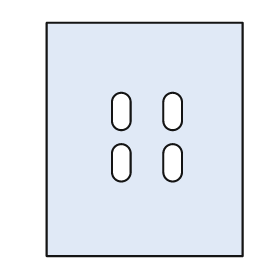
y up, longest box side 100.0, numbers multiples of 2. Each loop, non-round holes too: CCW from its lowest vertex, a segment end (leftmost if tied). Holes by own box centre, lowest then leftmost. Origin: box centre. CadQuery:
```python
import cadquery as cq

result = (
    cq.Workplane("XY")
    .moveTo(-42.0, -50.0)
    .lineTo(42.0, -50.0)
    .lineTo(42.0, 50.0)
    .lineTo(-42.0, 50.0)
    .close()
    .moveTo(-14.0, -14.0)
    .threePointArc((-10.0, -18.0), (-6.0, -14.0))
    .lineTo(-6.0, -6.0)
    .threePointArc((-10.0, -2.0), (-14.0, -6.0))
    .close()
    .moveTo(8.0, -14.0)
    .threePointArc((12.0, -18.0), (16.0, -14.0))
    .lineTo(16.0, -6.0)
    .threePointArc((12.0, -2.0), (8.0, -6.0))
    .close()
    .moveTo(-14.0, 8.0)
    .threePointArc((-10.0, 4.0), (-6.0, 8.0))
    .lineTo(-6.0, 16.0)
    .threePointArc((-10.0, 20.0), (-14.0, 16.0))
    .close()
    .moveTo(8.0, 8.0)
    .threePointArc((12.0, 4.0), (16.0, 8.0))
    .lineTo(16.0, 16.0)
    .threePointArc((12.0, 20.0), (8.0, 16.0))
    .close()
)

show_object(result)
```